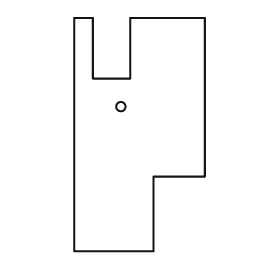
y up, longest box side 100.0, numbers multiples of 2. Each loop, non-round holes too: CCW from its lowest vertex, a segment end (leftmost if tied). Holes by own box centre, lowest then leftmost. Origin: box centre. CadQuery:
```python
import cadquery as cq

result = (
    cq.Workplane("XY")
    .moveTo(-28.0, -50.0)
    .lineTo(6.0, -50.0)
    .lineTo(6.0, -18.0)
    .lineTo(28.0, -18.0)
    .lineTo(28.0, 50.0)
    .lineTo(-4.0, 50.0)
    .lineTo(-4.0, 24.0)
    .lineTo(-20.0, 24.0)
    .lineTo(-20.0, 50.0)
    .lineTo(-28.0, 50.0)
    .close()
    .moveTo(-8.0, 12.0)
    .circle(2.0)
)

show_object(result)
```